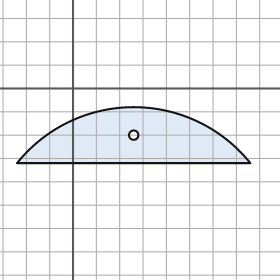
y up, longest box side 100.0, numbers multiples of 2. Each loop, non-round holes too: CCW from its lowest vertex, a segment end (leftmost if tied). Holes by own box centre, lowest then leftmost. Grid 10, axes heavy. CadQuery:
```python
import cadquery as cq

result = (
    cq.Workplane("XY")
    .moveTo(-24.0, -32.0)
    .lineTo(76.0, -32.0)
    .threePointArc((26.0, -8.0), (-24.0, -32.0))
    .close()
    .moveTo(26.0, -20.0)
    .circle(2.0)
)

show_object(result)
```